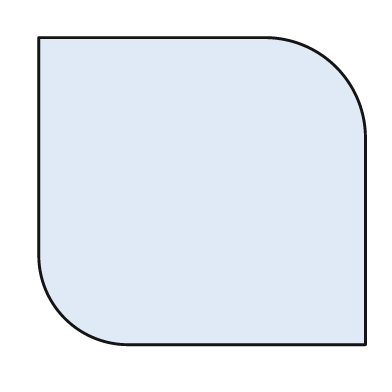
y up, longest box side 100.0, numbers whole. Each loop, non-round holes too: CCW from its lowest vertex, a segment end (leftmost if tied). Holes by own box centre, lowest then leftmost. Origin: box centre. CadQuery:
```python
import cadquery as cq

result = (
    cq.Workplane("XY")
    .moveTo(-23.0, -47.0)
    .lineTo(50.0, -47.0)
    .lineTo(50.0, 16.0)
    .threePointArc((41.0, 38.0), (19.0, 47.0))
    .lineTo(-50.0, 47.0)
    .lineTo(-50.0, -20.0)
    .threePointArc((-42.0, -39.0), (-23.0, -47.0))
    .close()
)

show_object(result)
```